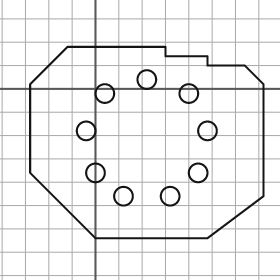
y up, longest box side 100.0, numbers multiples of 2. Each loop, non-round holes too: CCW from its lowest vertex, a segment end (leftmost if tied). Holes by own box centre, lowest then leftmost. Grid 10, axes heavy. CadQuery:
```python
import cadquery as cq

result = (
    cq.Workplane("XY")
    .moveTo(0.0, -64.0)
    .lineTo(48.0, -64.0)
    .lineTo(72.0, -46.0)
    .lineTo(72.0, 2.0)
    .lineTo(64.0, 10.0)
    .lineTo(48.0, 10.0)
    .lineTo(48.0, 14.0)
    .lineTo(30.0, 14.0)
    .lineTo(30.0, 18.0)
    .lineTo(-12.0, 18.0)
    .lineTo(-28.0, 2.0)
    .lineTo(-28.0, -36.0)
    .close()
    .moveTo(12.0, -46.0)
    .circle(4.0)
    .moveTo(32.0, -46.0)
    .circle(4.0)
    .moveTo(0.0, -36.0)
    .circle(4.0)
    .moveTo(44.0, -36.0)
    .circle(4.0)
    .moveTo(-4.0, -18.0)
    .circle(4.0)
    .moveTo(48.0, -18.0)
    .circle(4.0)
    .moveTo(4.0, -2.0)
    .circle(4.0)
    .moveTo(40.0, -2.0)
    .circle(4.0)
    .moveTo(22.0, 4.0)
    .circle(4.0)
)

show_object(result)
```